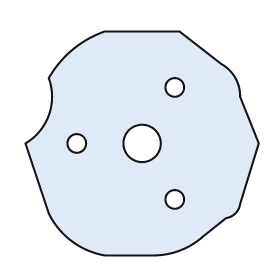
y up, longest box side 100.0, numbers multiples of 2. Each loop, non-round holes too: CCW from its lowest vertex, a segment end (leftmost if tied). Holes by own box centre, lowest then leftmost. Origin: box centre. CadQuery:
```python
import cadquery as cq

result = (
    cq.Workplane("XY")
    .moveTo(-16.0, -48.0)
    .lineTo(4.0, -48.0)
    .threePointArc((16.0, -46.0), (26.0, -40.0))
    .lineTo(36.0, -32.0)
    .threePointArc((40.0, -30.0), (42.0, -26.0))
    .lineTo(50.0, 0.0)
    .lineTo(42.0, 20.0)
    .threePointArc((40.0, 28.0), (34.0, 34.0))
    .lineTo(16.0, 48.0)
    .lineTo(-16.0, 48.0)
    .threePointArc((-30.0, 40.0), (-40.0, 28.0))
    .threePointArc((-40.0, 12.0), (-50.0, 0.0))
    .lineTo(-40.0, -30.0)
    .threePointArc((-30.0, -42.0), (-16.0, -48.0))
    .close()
    .moveTo(14.0, -24.0)
    .circle(4.0)
    .moveTo(-28.0, 0.0)
    .circle(4.0)
    .moveTo(0.0, 0.0)
    .circle(8.0)
    .moveTo(14.0, 24.0)
    .circle(4.0)
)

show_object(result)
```